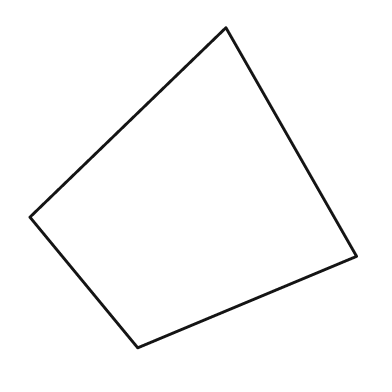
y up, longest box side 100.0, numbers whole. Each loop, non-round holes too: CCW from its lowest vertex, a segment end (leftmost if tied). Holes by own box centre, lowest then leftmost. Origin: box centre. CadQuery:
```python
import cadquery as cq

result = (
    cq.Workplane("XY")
    .moveTo(-17.0, -49.0)
    .lineTo(50.0, -21.0)
    .lineTo(10.0, 49.0)
    .lineTo(-50.0, -9.0)
    .close()
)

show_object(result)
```